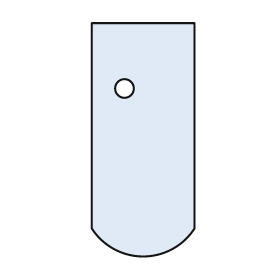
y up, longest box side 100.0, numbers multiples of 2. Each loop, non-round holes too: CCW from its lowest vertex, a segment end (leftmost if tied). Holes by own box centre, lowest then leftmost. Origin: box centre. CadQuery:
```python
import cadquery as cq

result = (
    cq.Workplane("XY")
    .moveTo(-22.0, -38.0)
    .threePointArc((0.0, -50.0), (22.0, -38.0))
    .lineTo(22.0, 50.0)
    .lineTo(-22.0, 50.0)
    .close()
    .moveTo(-8.0, 22.0)
    .circle(4.0)
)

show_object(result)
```